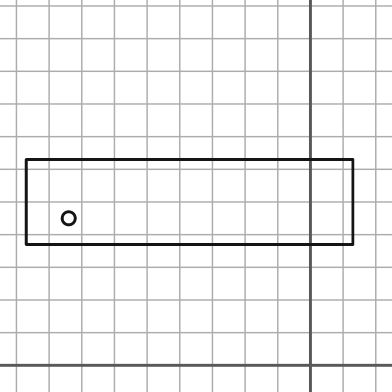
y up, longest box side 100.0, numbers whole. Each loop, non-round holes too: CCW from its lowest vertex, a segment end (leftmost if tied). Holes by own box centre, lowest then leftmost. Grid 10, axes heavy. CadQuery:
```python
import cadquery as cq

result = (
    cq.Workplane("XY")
    .moveTo(-87.0, 37.0)
    .lineTo(13.0, 37.0)
    .lineTo(13.0, 63.0)
    .lineTo(-87.0, 63.0)
    .close()
    .moveTo(-74.0, 45.0)
    .circle(2.0)
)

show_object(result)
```